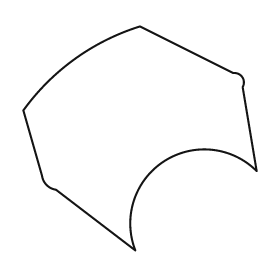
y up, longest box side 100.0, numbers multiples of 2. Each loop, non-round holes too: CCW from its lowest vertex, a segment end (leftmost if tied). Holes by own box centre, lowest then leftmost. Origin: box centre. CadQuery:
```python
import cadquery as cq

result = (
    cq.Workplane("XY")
    .moveTo(-2.0, -48.0)
    .threePointArc((10.0, -10.0), (50.0, -14.0))
    .lineTo(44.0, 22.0)
    .threePointArc((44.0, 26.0), (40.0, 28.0))
    .lineTo(0.0, 48.0)
    .threePointArc((-28.0, 34.0), (-50.0, 12.0))
    .lineTo(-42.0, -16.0)
    .threePointArc((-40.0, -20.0), (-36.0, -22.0))
    .close()
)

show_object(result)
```